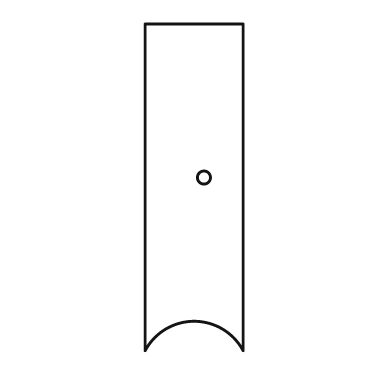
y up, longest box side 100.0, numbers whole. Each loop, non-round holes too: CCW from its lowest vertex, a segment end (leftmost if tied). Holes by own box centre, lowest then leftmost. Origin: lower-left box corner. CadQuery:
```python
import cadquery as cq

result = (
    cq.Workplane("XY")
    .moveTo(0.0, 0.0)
    .threePointArc((15.0, 9.0), (30.0, 0.0))
    .lineTo(30.0, 100.0)
    .lineTo(0.0, 100.0)
    .close()
    .moveTo(18.0, 53.0)
    .circle(2.0)
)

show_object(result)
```